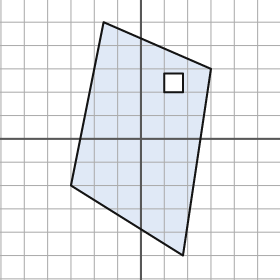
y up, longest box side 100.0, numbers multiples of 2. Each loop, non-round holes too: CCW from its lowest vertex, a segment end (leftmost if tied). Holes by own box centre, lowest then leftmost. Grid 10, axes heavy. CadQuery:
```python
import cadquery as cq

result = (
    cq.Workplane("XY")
    .moveTo(18.0, -50.0)
    .lineTo(30.0, 30.0)
    .lineTo(-16.0, 50.0)
    .lineTo(-30.0, -20.0)
    .close()
    .moveTo(10.0, 20.0)
    .lineTo(18.0, 20.0)
    .lineTo(18.0, 28.0)
    .lineTo(10.0, 28.0)
    .close()
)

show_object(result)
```